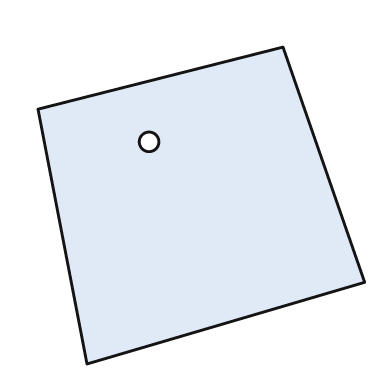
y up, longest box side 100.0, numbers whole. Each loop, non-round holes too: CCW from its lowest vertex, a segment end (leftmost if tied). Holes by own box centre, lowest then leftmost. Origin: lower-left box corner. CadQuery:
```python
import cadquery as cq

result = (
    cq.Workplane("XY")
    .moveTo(15.0, 0.0)
    .lineTo(100.0, 25.0)
    .lineTo(75.0, 97.0)
    .lineTo(0.0, 78.0)
    .close()
    .moveTo(34.0, 68.0)
    .circle(3.0)
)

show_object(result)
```